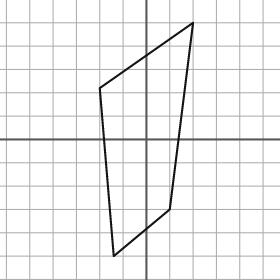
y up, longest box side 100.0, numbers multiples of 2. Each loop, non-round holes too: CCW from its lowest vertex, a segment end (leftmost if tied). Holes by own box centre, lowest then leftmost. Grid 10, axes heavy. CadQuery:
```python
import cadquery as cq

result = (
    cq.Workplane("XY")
    .moveTo(-14.0, -50.0)
    .lineTo(10.0, -30.0)
    .lineTo(20.0, 50.0)
    .lineTo(-20.0, 22.0)
    .close()
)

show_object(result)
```